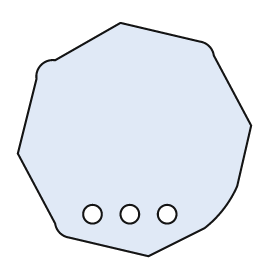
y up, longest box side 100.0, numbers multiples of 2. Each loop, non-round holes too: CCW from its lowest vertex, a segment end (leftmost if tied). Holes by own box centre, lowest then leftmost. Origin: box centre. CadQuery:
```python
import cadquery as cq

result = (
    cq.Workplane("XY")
    .moveTo(6.0, -50.0)
    .lineTo(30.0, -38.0)
    .threePointArc((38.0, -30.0), (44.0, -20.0))
    .lineTo(50.0, 6.0)
    .lineTo(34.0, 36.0)
    .threePointArc((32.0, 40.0), (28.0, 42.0))
    .lineTo(-6.0, 50.0)
    .lineTo(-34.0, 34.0)
    .threePointArc((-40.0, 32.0), (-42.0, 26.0))
    .lineTo(-50.0, -6.0)
    .lineTo(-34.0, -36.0)
    .threePointArc((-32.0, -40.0), (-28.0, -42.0))
    .close()
    .moveTo(-18.0, -32.0)
    .circle(4.0)
    .moveTo(-2.0, -32.0)
    .circle(4.0)
    .moveTo(14.0, -32.0)
    .circle(4.0)
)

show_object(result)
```